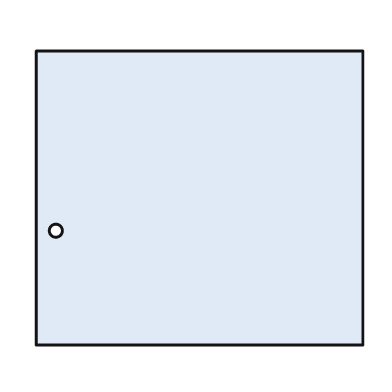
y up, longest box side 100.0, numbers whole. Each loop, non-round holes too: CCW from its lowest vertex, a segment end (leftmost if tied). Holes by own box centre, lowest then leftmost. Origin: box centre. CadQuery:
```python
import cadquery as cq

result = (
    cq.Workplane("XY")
    .moveTo(-50.0, -45.0)
    .lineTo(50.0, -45.0)
    .lineTo(50.0, 45.0)
    .lineTo(-50.0, 45.0)
    .close()
    .moveTo(-44.0, -10.0)
    .circle(2.0)
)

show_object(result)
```